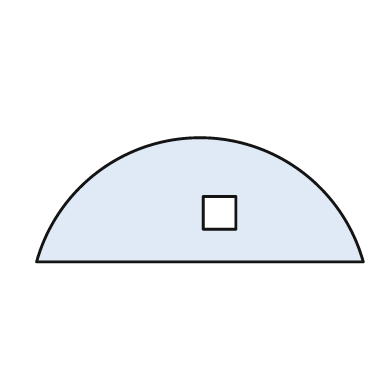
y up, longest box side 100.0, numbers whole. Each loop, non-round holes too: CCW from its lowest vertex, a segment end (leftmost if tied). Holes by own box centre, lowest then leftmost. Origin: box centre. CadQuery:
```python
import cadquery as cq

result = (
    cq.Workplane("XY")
    .moveTo(-50.0, -19.0)
    .lineTo(50.0, -19.0)
    .threePointArc((0.0, 19.0), (-50.0, -19.0))
    .close()
    .moveTo(1.0, -9.0)
    .lineTo(11.0, -9.0)
    .lineTo(11.0, 1.0)
    .lineTo(1.0, 1.0)
    .close()
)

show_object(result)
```